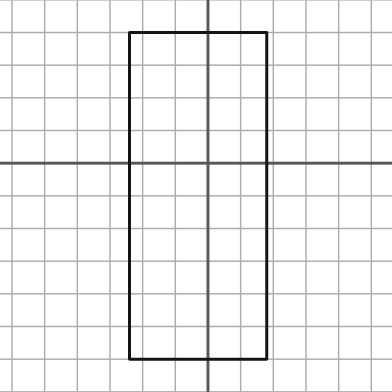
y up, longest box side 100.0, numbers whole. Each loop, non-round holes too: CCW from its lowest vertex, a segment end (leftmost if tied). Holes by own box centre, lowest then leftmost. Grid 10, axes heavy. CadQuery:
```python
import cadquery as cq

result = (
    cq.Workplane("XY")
    .moveTo(-24.0, -60.0)
    .lineTo(18.0, -60.0)
    .lineTo(18.0, 40.0)
    .lineTo(-24.0, 40.0)
    .close()
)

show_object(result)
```